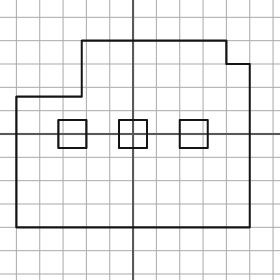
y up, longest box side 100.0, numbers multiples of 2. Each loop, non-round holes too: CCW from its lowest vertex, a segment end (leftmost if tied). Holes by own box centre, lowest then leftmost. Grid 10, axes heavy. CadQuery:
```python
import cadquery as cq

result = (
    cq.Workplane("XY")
    .moveTo(-50.0, -40.0)
    .lineTo(50.0, -40.0)
    .lineTo(50.0, 30.0)
    .lineTo(40.0, 30.0)
    .lineTo(40.0, 40.0)
    .lineTo(-22.0, 40.0)
    .lineTo(-22.0, 16.0)
    .lineTo(-50.0, 16.0)
    .close()
    .moveTo(-32.0, -6.0)
    .lineTo(-20.0, -6.0)
    .lineTo(-20.0, 6.0)
    .lineTo(-32.0, 6.0)
    .close()
    .moveTo(-6.0, -6.0)
    .lineTo(6.0, -6.0)
    .lineTo(6.0, 6.0)
    .lineTo(-6.0, 6.0)
    .close()
    .moveTo(20.0, -6.0)
    .lineTo(32.0, -6.0)
    .lineTo(32.0, 6.0)
    .lineTo(20.0, 6.0)
    .close()
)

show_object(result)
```